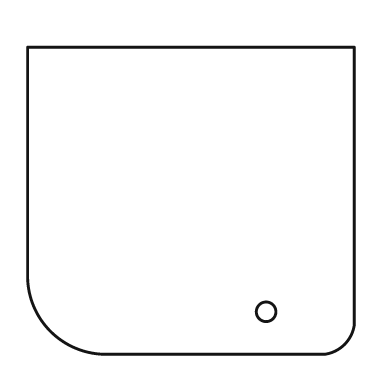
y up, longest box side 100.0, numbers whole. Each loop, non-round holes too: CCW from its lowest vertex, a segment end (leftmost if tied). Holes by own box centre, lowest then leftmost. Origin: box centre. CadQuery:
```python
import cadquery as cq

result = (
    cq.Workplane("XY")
    .moveTo(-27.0, -47.0)
    .lineTo(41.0, -47.0)
    .threePointArc((47.0, -44.0), (50.0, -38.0))
    .lineTo(50.0, 47.0)
    .lineTo(-50.0, 47.0)
    .lineTo(-50.0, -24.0)
    .threePointArc((-43.0, -40.0), (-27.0, -47.0))
    .close()
    .moveTo(23.0, -34.0)
    .circle(3.0)
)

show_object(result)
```